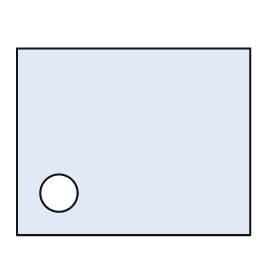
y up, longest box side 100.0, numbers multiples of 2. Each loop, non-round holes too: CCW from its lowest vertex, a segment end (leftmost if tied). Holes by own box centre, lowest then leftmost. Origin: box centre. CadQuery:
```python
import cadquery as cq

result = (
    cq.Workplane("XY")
    .moveTo(-50.0, -40.0)
    .lineTo(50.0, -40.0)
    .lineTo(50.0, 40.0)
    .lineTo(-50.0, 40.0)
    .close()
    .moveTo(-32.0, -22.0)
    .circle(8.0)
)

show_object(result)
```